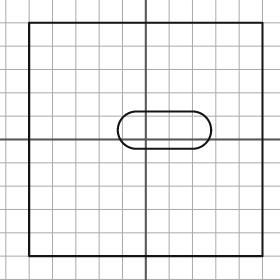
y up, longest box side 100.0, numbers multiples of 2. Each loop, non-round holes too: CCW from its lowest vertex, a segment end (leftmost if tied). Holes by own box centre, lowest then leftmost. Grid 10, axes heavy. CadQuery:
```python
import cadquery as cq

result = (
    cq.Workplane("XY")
    .moveTo(-50.0, -50.0)
    .lineTo(50.0, -50.0)
    .lineTo(50.0, 50.0)
    .lineTo(-50.0, 50.0)
    .close()
    .moveTo(-4.0, -4.0)
    .lineTo(20.0, -4.0)
    .threePointArc((28.0, 4.0), (20.0, 12.0))
    .lineTo(-4.0, 12.0)
    .threePointArc((-12.0, 4.0), (-4.0, -4.0))
    .close()
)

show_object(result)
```